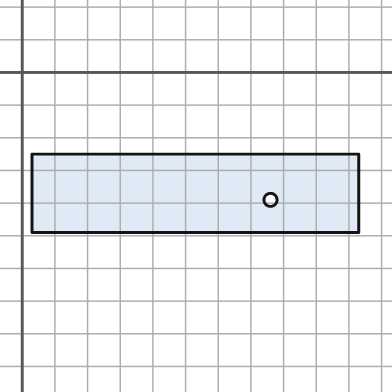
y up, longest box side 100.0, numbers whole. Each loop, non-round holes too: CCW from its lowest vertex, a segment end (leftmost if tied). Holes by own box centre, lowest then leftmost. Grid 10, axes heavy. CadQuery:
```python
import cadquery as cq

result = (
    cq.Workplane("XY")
    .moveTo(3.0, -49.0)
    .lineTo(103.0, -49.0)
    .lineTo(103.0, -25.0)
    .lineTo(3.0, -25.0)
    .close()
    .moveTo(76.0, -39.0)
    .circle(2.0)
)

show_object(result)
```